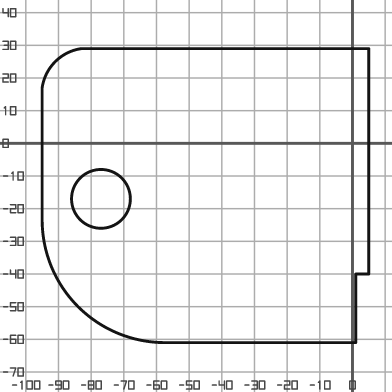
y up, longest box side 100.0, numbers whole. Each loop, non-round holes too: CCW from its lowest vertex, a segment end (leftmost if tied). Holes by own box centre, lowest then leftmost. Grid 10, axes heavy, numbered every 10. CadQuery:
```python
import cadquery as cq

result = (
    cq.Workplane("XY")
    .moveTo(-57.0, -61.0)
    .lineTo(1.0, -61.0)
    .lineTo(1.0, -40.0)
    .lineTo(5.0, -40.0)
    .lineTo(5.0, 29.0)
    .lineTo(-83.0, 29.0)
    .threePointArc((-91.0, 25.0), (-95.0, 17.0))
    .lineTo(-95.0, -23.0)
    .threePointArc((-84.0, -50.0), (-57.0, -61.0))
    .close()
    .moveTo(-77.0, -17.0)
    .circle(9.0)
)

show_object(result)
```